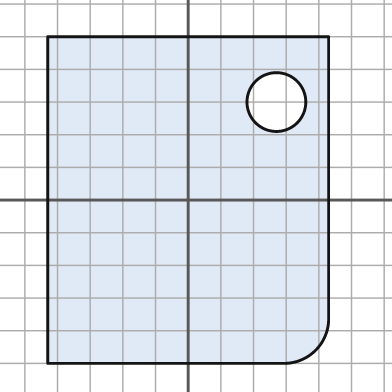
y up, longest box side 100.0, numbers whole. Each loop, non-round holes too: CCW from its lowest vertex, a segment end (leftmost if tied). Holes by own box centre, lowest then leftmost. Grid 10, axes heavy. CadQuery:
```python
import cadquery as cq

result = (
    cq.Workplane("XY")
    .moveTo(-43.0, -50.0)
    .lineTo(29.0, -50.0)
    .threePointArc((39.0, -46.0), (43.0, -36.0))
    .lineTo(43.0, 50.0)
    .lineTo(-43.0, 50.0)
    .close()
    .moveTo(27.0, 30.0)
    .circle(9.0)
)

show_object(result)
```